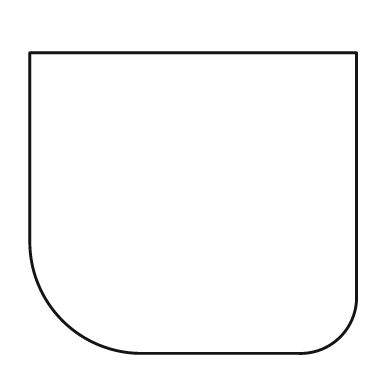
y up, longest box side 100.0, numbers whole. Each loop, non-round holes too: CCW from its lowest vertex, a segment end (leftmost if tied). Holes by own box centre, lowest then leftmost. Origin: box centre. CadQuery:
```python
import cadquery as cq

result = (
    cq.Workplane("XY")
    .moveTo(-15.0, -46.0)
    .lineTo(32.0, -46.0)
    .threePointArc((45.0, -41.0), (50.0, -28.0))
    .lineTo(50.0, 46.0)
    .lineTo(-50.0, 46.0)
    .lineTo(-50.0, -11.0)
    .threePointArc((-40.0, -36.0), (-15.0, -46.0))
    .close()
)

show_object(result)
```